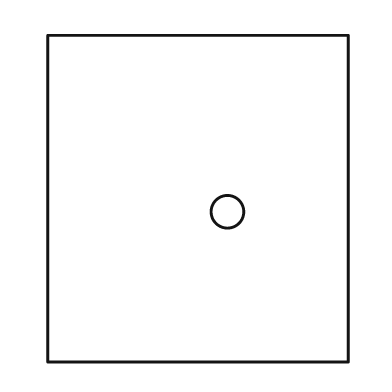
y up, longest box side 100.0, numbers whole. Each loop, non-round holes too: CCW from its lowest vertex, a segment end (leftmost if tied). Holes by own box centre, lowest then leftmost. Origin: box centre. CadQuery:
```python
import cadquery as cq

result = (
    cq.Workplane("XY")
    .moveTo(-46.0, -50.0)
    .lineTo(46.0, -50.0)
    .lineTo(46.0, 50.0)
    .lineTo(-46.0, 50.0)
    .close()
    .moveTo(9.0, -4.0)
    .circle(5.0)
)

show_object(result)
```